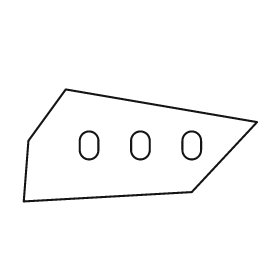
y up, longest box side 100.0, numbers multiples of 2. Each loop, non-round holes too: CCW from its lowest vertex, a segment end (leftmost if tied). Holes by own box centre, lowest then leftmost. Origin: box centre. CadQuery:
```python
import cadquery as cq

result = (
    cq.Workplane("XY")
    .moveTo(-50.0, -24.0)
    .lineTo(22.0, -20.0)
    .lineTo(50.0, 10.0)
    .lineTo(-32.0, 24.0)
    .lineTo(-48.0, 2.0)
    .close()
    .moveTo(-26.0, -2.0)
    .threePointArc((-22.0, -6.0), (-18.0, -2.0))
    .lineTo(-18.0, 2.0)
    .threePointArc((-22.0, 6.0), (-26.0, 2.0))
    .close()
    .moveTo(-4.0, -2.0)
    .threePointArc((0.0, -6.0), (4.0, -2.0))
    .lineTo(4.0, 2.0)
    .threePointArc((0.0, 6.0), (-4.0, 2.0))
    .close()
    .moveTo(18.0, -2.0)
    .threePointArc((22.0, -6.0), (26.0, -2.0))
    .lineTo(26.0, 2.0)
    .threePointArc((22.0, 6.0), (18.0, 2.0))
    .close()
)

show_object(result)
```